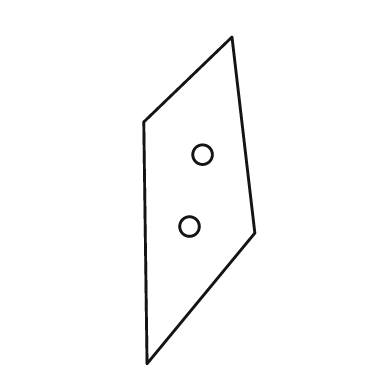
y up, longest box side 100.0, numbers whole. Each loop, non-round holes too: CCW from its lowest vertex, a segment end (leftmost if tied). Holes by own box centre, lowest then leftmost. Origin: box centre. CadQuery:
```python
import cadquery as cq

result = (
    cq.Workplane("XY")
    .moveTo(-16.0, -50.0)
    .lineTo(17.0, -10.0)
    .lineTo(10.0, 50.0)
    .lineTo(-17.0, 24.0)
    .close()
    .moveTo(-3.0, -8.0)
    .circle(3.0)
    .moveTo(1.0, 14.0)
    .circle(3.0)
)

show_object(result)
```